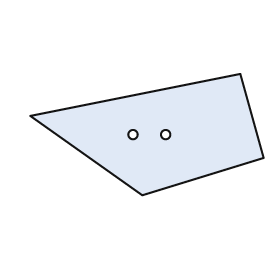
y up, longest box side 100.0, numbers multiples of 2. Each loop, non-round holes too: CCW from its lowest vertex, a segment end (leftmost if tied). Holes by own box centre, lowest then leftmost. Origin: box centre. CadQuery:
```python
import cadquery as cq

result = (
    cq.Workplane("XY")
    .moveTo(-2.0, -26.0)
    .lineTo(50.0, -10.0)
    .lineTo(40.0, 26.0)
    .lineTo(-50.0, 8.0)
    .close()
    .moveTo(-6.0, 0.0)
    .circle(2.0)
    .moveTo(8.0, 0.0)
    .circle(2.0)
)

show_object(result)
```